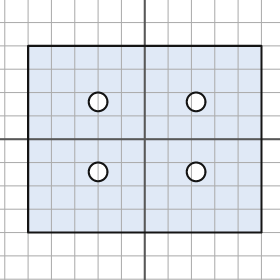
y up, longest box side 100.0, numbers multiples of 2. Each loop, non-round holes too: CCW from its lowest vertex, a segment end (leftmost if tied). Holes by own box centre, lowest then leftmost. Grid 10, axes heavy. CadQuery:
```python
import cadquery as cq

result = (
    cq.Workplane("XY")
    .moveTo(-50.0, -40.0)
    .lineTo(50.0, -40.0)
    .lineTo(50.0, 40.0)
    .lineTo(-50.0, 40.0)
    .close()
    .moveTo(-20.0, -14.0)
    .circle(4.0)
    .moveTo(22.0, -14.0)
    .circle(4.0)
    .moveTo(-20.0, 16.0)
    .circle(4.0)
    .moveTo(22.0, 16.0)
    .circle(4.0)
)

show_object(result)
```